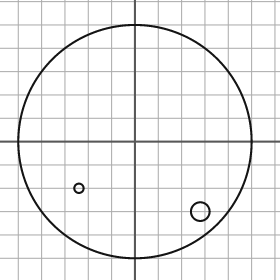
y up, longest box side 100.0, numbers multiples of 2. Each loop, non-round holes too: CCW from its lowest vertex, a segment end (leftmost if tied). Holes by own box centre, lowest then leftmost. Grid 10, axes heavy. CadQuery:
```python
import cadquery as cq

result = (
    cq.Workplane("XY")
    .moveTo(0.0, 0.0)
    .circle(50.0)
    .moveTo(28.0, -30.0)
    .circle(4.0)
    .moveTo(-24.0, -20.0)
    .circle(2.0)
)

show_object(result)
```